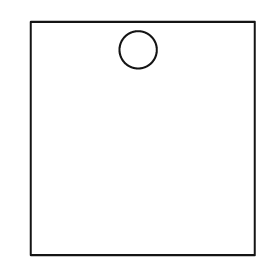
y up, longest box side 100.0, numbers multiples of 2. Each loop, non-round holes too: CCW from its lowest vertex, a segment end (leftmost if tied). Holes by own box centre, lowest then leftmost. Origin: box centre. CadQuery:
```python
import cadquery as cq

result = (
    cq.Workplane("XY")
    .moveTo(-48.0, -50.0)
    .lineTo(48.0, -50.0)
    .lineTo(48.0, 50.0)
    .lineTo(-48.0, 50.0)
    .close()
    .moveTo(-2.0, 38.0)
    .circle(8.0)
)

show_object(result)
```